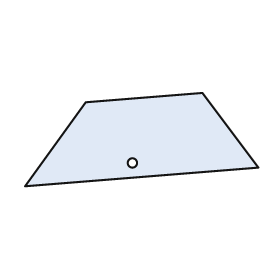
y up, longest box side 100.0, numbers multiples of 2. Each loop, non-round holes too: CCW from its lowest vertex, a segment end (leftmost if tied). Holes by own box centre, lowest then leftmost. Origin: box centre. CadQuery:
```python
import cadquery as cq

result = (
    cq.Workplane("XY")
    .moveTo(-50.0, -20.0)
    .lineTo(50.0, -12.0)
    .lineTo(26.0, 20.0)
    .lineTo(-24.0, 16.0)
    .close()
    .moveTo(-4.0, -10.0)
    .circle(2.0)
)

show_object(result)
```